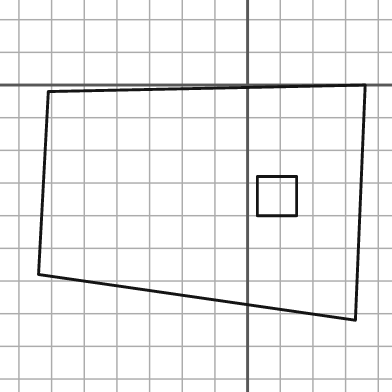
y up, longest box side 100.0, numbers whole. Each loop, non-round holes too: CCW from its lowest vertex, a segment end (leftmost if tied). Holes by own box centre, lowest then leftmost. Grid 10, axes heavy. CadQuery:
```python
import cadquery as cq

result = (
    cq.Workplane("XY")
    .moveTo(33.0, -72.0)
    .lineTo(36.0, 0.0)
    .lineTo(-61.0, -2.0)
    .lineTo(-64.0, -58.0)
    .close()
    .moveTo(3.0, -40.0)
    .lineTo(15.0, -40.0)
    .lineTo(15.0, -28.0)
    .lineTo(3.0, -28.0)
    .close()
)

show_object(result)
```